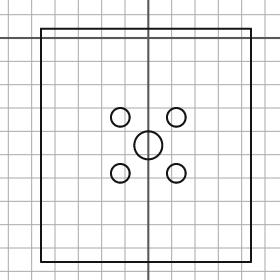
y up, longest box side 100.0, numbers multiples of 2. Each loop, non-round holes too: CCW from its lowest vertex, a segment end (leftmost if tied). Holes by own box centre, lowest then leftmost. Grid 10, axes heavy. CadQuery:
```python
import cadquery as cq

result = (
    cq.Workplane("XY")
    .moveTo(-46.0, -96.0)
    .lineTo(44.0, -96.0)
    .lineTo(44.0, 4.0)
    .lineTo(-46.0, 4.0)
    .close()
    .moveTo(-12.0, -58.0)
    .circle(4.0)
    .moveTo(12.0, -58.0)
    .circle(4.0)
    .moveTo(0.0, -46.0)
    .circle(6.0)
    .moveTo(-12.0, -34.0)
    .circle(4.0)
    .moveTo(12.0, -34.0)
    .circle(4.0)
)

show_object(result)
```